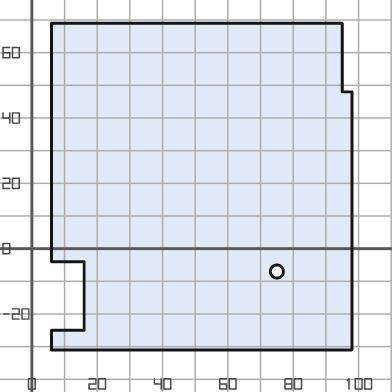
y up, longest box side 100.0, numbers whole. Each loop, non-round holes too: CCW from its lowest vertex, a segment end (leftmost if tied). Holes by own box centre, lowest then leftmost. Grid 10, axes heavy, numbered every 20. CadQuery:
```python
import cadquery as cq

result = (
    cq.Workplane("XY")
    .moveTo(6.0, -31.0)
    .lineTo(98.0, -31.0)
    .lineTo(98.0, 48.0)
    .lineTo(95.0, 48.0)
    .lineTo(95.0, 69.0)
    .lineTo(6.0, 69.0)
    .lineTo(6.0, -4.0)
    .lineTo(16.0, -4.0)
    .lineTo(16.0, -25.0)
    .lineTo(6.0, -25.0)
    .close()
    .moveTo(75.0, -7.0)
    .circle(2.0)
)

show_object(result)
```